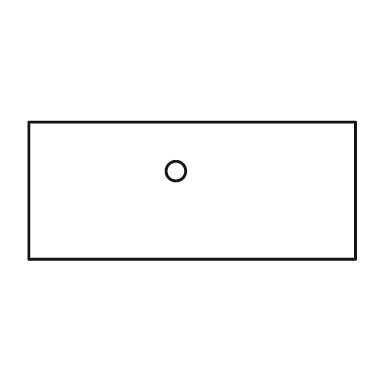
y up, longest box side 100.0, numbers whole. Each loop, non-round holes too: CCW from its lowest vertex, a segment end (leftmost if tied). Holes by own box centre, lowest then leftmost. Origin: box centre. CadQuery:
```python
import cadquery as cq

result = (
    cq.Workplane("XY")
    .moveTo(-50.0, -21.0)
    .lineTo(50.0, -21.0)
    .lineTo(50.0, 21.0)
    .lineTo(-50.0, 21.0)
    .close()
    .moveTo(-5.0, 6.0)
    .circle(3.0)
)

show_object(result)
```